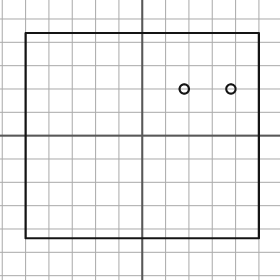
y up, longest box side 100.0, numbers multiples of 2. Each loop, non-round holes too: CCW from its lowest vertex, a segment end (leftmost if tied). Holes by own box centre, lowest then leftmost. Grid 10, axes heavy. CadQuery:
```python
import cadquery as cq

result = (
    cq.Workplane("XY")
    .moveTo(-50.0, -44.0)
    .lineTo(50.0, -44.0)
    .lineTo(50.0, 44.0)
    .lineTo(-50.0, 44.0)
    .close()
    .moveTo(18.0, 20.0)
    .circle(2.0)
    .moveTo(38.0, 20.0)
    .circle(2.0)
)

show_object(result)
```